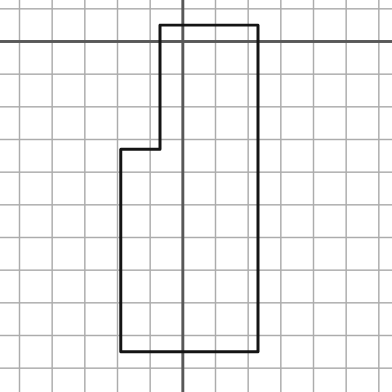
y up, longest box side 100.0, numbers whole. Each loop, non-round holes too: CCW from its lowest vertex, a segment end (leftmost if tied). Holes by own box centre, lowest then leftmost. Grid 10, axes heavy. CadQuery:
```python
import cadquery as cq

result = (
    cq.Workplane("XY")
    .moveTo(-19.0, -95.0)
    .lineTo(23.0, -95.0)
    .lineTo(23.0, 5.0)
    .lineTo(-7.0, 5.0)
    .lineTo(-7.0, -33.0)
    .lineTo(-19.0, -33.0)
    .close()
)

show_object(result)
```